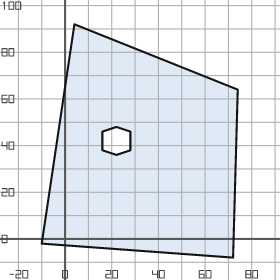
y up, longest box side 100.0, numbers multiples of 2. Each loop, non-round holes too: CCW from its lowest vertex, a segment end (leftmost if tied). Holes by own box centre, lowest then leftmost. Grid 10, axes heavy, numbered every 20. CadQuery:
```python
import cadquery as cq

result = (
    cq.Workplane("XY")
    .moveTo(72.0, -8.0)
    .lineTo(74.0, 64.0)
    .lineTo(4.0, 92.0)
    .lineTo(-10.0, -2.0)
    .close()
    .moveTo(22.0, 36.0)
    .lineTo(28.0, 38.0)
    .lineTo(28.0, 46.0)
    .lineTo(22.0, 48.0)
    .lineTo(16.0, 46.0)
    .lineTo(16.0, 38.0)
    .close()
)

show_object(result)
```